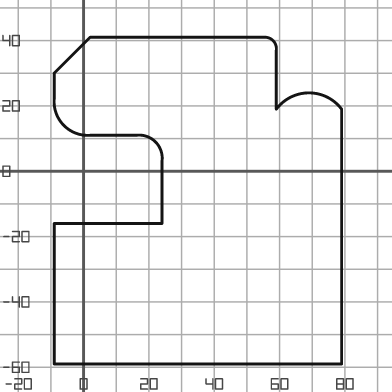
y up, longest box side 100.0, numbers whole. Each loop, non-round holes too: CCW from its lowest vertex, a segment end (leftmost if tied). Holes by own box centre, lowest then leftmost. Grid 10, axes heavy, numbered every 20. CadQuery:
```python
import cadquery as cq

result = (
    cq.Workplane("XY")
    .moveTo(-9.0, -59.0)
    .lineTo(79.0, -59.0)
    .lineTo(79.0, 19.0)
    .threePointArc((69.0, 24.0), (59.0, 19.0))
    .lineTo(59.0, 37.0)
    .threePointArc((58.0, 40.0), (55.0, 41.0))
    .lineTo(2.0, 41.0)
    .lineTo(-9.0, 30.0)
    .lineTo(-9.0, 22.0)
    .threePointArc((-6.0, 14.0), (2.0, 11.0))
    .lineTo(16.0, 11.0)
    .threePointArc((22.0, 9.0), (24.0, 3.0))
    .lineTo(24.0, -16.0)
    .lineTo(-9.0, -16.0)
    .close()
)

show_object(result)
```